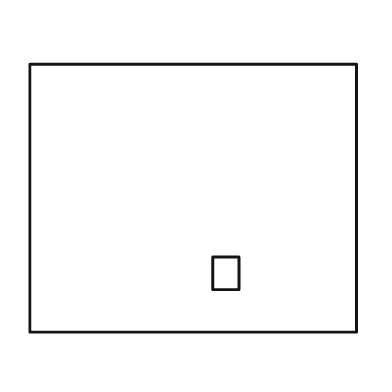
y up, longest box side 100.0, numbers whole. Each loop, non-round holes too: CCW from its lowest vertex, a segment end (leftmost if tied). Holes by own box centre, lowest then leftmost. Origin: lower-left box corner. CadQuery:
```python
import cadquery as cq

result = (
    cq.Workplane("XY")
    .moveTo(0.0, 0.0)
    .lineTo(100.0, 0.0)
    .lineTo(100.0, 82.0)
    .lineTo(0.0, 82.0)
    .close()
    .moveTo(56.0, 13.0)
    .lineTo(64.0, 13.0)
    .lineTo(64.0, 23.0)
    .lineTo(56.0, 23.0)
    .close()
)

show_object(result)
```